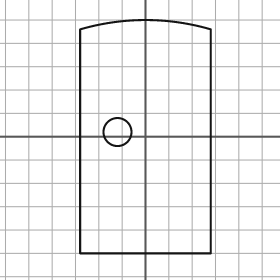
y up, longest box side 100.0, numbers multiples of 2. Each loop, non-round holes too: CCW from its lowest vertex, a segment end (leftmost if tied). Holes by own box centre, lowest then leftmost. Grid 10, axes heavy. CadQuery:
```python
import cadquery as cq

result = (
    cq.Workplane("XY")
    .moveTo(-28.0, -50.0)
    .lineTo(28.0, -50.0)
    .lineTo(28.0, 46.0)
    .threePointArc((0.0, 50.0), (-28.0, 46.0))
    .close()
    .moveTo(-12.0, 2.0)
    .circle(6.0)
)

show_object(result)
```